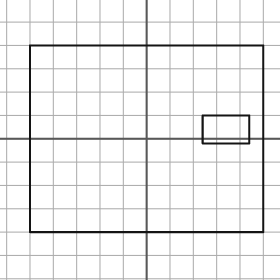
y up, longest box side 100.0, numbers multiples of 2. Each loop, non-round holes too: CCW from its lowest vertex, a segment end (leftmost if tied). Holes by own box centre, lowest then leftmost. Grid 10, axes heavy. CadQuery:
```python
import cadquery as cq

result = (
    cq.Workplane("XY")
    .moveTo(-50.0, -40.0)
    .lineTo(50.0, -40.0)
    .lineTo(50.0, 40.0)
    .lineTo(-50.0, 40.0)
    .close()
    .moveTo(24.0, -2.0)
    .lineTo(44.0, -2.0)
    .lineTo(44.0, 10.0)
    .lineTo(24.0, 10.0)
    .close()
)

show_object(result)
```